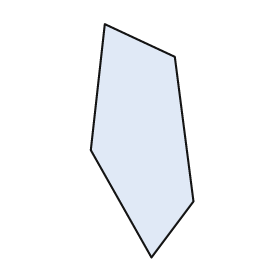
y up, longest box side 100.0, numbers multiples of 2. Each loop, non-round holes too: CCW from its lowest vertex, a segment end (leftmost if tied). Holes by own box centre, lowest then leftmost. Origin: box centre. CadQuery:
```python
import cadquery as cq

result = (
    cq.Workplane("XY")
    .moveTo(4.0, -50.0)
    .lineTo(22.0, -26.0)
    .lineTo(14.0, 36.0)
    .lineTo(-16.0, 50.0)
    .lineTo(-22.0, -4.0)
    .close()
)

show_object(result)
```